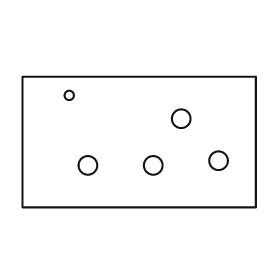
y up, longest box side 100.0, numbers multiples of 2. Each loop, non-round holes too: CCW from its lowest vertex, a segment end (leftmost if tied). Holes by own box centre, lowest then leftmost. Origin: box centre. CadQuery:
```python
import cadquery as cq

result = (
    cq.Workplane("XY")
    .moveTo(-50.0, -28.0)
    .lineTo(50.0, -28.0)
    .lineTo(50.0, 28.0)
    .lineTo(-50.0, 28.0)
    .close()
    .moveTo(-22.0, -10.0)
    .circle(4.0)
    .moveTo(6.0, -10.0)
    .circle(4.0)
    .moveTo(34.0, -8.0)
    .circle(4.0)
    .moveTo(18.0, 10.0)
    .circle(4.0)
    .moveTo(-30.0, 20.0)
    .circle(2.0)
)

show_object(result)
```